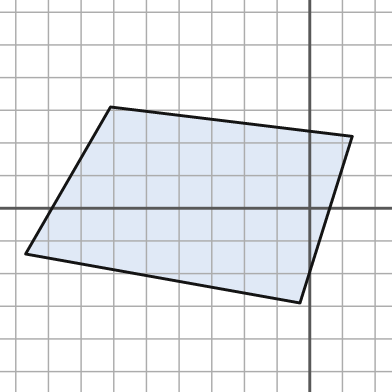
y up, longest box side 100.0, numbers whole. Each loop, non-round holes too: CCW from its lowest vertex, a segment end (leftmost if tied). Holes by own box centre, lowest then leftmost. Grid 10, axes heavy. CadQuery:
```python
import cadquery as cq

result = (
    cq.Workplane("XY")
    .moveTo(-3.0, -29.0)
    .lineTo(13.0, 22.0)
    .lineTo(-61.0, 31.0)
    .lineTo(-87.0, -14.0)
    .close()
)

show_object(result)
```